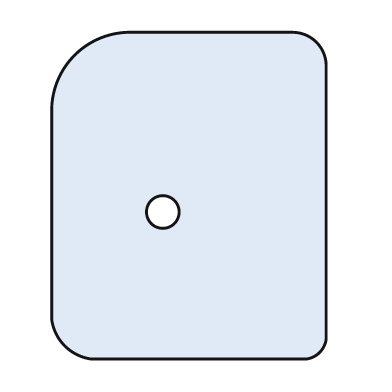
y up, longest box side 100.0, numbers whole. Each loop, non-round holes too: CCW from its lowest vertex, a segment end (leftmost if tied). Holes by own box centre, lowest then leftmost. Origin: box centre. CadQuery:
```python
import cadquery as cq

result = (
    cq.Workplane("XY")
    .moveTo(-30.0, -50.0)
    .lineTo(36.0, -50.0)
    .threePointArc((40.0, -48.0), (42.0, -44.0))
    .lineTo(42.0, 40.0)
    .threePointArc((39.0, 47.0), (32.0, 50.0))
    .lineTo(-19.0, 50.0)
    .threePointArc((-35.0, 43.0), (-42.0, 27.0))
    .lineTo(-42.0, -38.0)
    .threePointArc((-38.0, -46.0), (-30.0, -50.0))
    .close()
    .moveTo(-8.0, -5.0)
    .circle(5.0)
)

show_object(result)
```